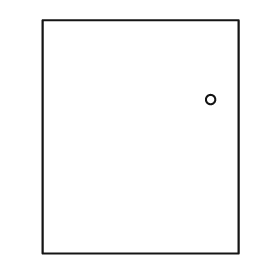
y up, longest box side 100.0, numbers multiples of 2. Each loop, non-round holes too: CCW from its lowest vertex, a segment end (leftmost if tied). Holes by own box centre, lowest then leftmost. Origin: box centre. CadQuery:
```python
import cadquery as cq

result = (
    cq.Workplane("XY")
    .moveTo(-42.0, -50.0)
    .lineTo(42.0, -50.0)
    .lineTo(42.0, 50.0)
    .lineTo(-42.0, 50.0)
    .close()
    .moveTo(30.0, 16.0)
    .circle(2.0)
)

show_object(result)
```